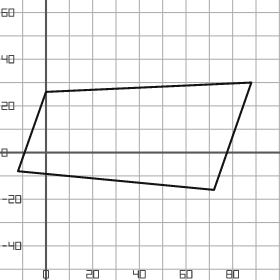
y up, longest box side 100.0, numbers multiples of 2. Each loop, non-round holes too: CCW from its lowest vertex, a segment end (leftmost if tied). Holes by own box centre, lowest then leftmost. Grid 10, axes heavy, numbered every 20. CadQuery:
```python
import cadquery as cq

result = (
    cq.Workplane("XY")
    .moveTo(72.0, -16.0)
    .lineTo(88.0, 30.0)
    .lineTo(0.0, 26.0)
    .lineTo(-12.0, -8.0)
    .close()
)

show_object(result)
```